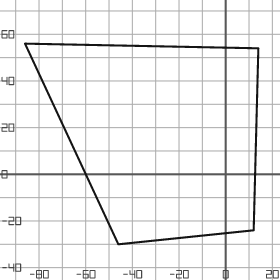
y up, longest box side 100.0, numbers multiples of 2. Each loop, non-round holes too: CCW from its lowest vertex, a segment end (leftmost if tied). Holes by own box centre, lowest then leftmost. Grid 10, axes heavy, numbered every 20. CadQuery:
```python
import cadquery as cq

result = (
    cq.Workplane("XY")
    .moveTo(-46.0, -30.0)
    .lineTo(12.0, -24.0)
    .lineTo(14.0, 54.0)
    .lineTo(-86.0, 56.0)
    .close()
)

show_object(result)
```